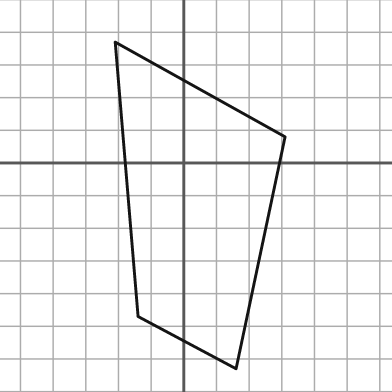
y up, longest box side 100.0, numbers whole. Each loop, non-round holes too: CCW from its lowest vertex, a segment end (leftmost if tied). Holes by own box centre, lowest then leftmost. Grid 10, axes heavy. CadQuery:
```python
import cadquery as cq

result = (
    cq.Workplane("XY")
    .moveTo(16.0, -63.0)
    .lineTo(31.0, 8.0)
    .lineTo(-21.0, 37.0)
    .lineTo(-14.0, -47.0)
    .close()
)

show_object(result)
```